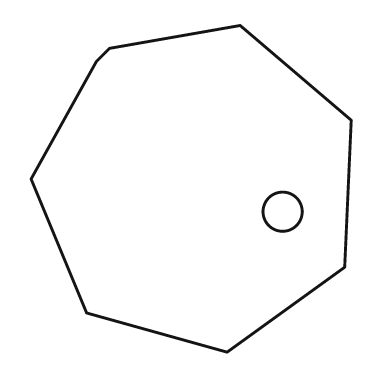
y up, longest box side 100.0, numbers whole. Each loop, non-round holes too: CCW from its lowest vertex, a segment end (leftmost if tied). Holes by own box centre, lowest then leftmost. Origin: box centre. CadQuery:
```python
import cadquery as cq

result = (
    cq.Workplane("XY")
    .moveTo(11.0, -50.0)
    .lineTo(47.0, -24.0)
    .lineTo(49.0, 21.0)
    .lineTo(15.0, 50.0)
    .lineTo(-25.0, 43.0)
    .lineTo(-29.0, 39.0)
    .lineTo(-49.0, 3.0)
    .lineTo(-32.0, -38.0)
    .close()
    .moveTo(28.0, -7.0)
    .circle(6.0)
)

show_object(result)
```